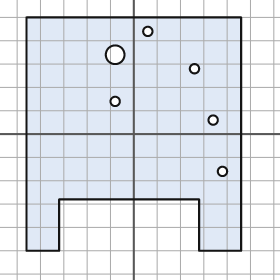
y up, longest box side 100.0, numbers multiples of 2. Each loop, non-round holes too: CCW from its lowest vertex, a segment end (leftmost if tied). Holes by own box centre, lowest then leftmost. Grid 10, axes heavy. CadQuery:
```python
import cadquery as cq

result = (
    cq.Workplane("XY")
    .moveTo(-46.0, -50.0)
    .lineTo(-32.0, -50.0)
    .lineTo(-32.0, -28.0)
    .lineTo(28.0, -28.0)
    .lineTo(28.0, -50.0)
    .lineTo(46.0, -50.0)
    .lineTo(46.0, 50.0)
    .lineTo(-46.0, 50.0)
    .close()
    .moveTo(38.0, -16.0)
    .circle(2.0)
    .moveTo(34.0, 6.0)
    .circle(2.0)
    .moveTo(-8.0, 14.0)
    .circle(2.0)
    .moveTo(26.0, 28.0)
    .circle(2.0)
    .moveTo(-8.0, 34.0)
    .circle(4.0)
    .moveTo(6.0, 44.0)
    .circle(2.0)
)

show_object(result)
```